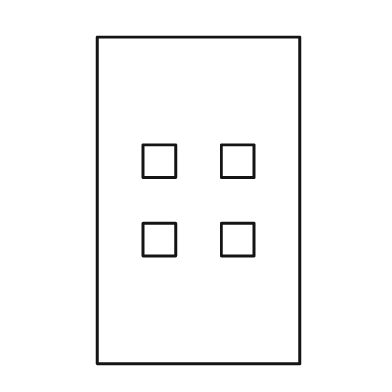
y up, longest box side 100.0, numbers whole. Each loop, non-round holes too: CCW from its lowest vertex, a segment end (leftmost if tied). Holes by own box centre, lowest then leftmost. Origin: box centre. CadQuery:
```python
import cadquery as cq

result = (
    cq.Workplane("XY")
    .moveTo(-31.0, -50.0)
    .lineTo(31.0, -50.0)
    .lineTo(31.0, 50.0)
    .lineTo(-31.0, 50.0)
    .close()
    .moveTo(-17.0, -17.0)
    .lineTo(-7.0, -17.0)
    .lineTo(-7.0, -7.0)
    .lineTo(-17.0, -7.0)
    .close()
    .moveTo(7.0, -17.0)
    .lineTo(17.0, -17.0)
    .lineTo(17.0, -7.0)
    .lineTo(7.0, -7.0)
    .close()
    .moveTo(-17.0, 7.0)
    .lineTo(-7.0, 7.0)
    .lineTo(-7.0, 17.0)
    .lineTo(-17.0, 17.0)
    .close()
    .moveTo(7.0, 7.0)
    .lineTo(17.0, 7.0)
    .lineTo(17.0, 17.0)
    .lineTo(7.0, 17.0)
    .close()
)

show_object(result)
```